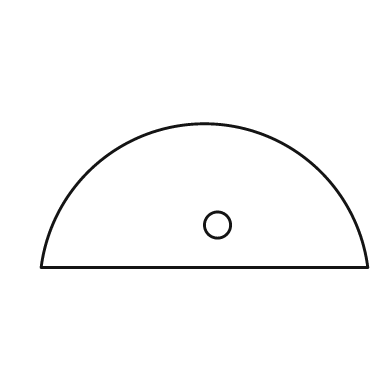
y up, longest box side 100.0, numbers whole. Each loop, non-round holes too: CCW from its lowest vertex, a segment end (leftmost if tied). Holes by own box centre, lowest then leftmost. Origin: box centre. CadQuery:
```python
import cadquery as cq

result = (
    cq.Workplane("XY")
    .moveTo(-50.0, -22.0)
    .lineTo(50.0, -22.0)
    .threePointArc((0.0, 22.0), (-50.0, -22.0))
    .close()
    .moveTo(4.0, -9.0)
    .circle(4.0)
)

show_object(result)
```